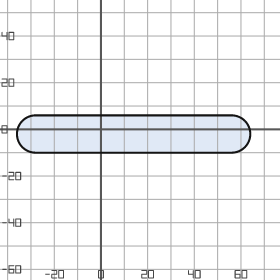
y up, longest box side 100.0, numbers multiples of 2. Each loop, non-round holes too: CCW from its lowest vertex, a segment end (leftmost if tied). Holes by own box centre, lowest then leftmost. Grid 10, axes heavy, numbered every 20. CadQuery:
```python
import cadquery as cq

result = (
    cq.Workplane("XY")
    .moveTo(-28.0, -10.0)
    .lineTo(56.0, -10.0)
    .threePointArc((64.0, -2.0), (56.0, 6.0))
    .lineTo(-28.0, 6.0)
    .threePointArc((-36.0, -2.0), (-28.0, -10.0))
    .close()
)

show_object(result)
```